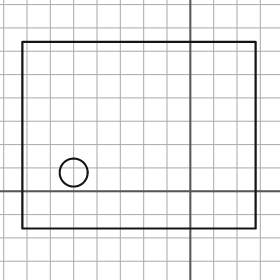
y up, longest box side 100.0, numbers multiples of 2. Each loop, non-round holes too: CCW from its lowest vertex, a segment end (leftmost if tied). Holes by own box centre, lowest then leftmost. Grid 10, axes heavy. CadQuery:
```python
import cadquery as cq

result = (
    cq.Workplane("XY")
    .moveTo(-72.0, -16.0)
    .lineTo(28.0, -16.0)
    .lineTo(28.0, 64.0)
    .lineTo(-72.0, 64.0)
    .close()
    .moveTo(-50.0, 8.0)
    .circle(6.0)
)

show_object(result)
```